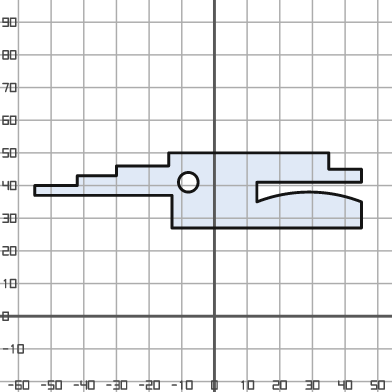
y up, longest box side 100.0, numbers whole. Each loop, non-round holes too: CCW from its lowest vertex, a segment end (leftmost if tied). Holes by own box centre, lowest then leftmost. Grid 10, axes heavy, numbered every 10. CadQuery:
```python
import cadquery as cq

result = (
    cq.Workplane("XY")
    .moveTo(-13.0, 27.0)
    .lineTo(45.0, 27.0)
    .lineTo(45.0, 35.0)
    .threePointArc((29.0, 38.0), (13.0, 35.0))
    .lineTo(13.0, 41.0)
    .lineTo(45.0, 41.0)
    .lineTo(45.0, 45.0)
    .lineTo(35.0, 45.0)
    .lineTo(35.0, 50.0)
    .lineTo(-14.0, 50.0)
    .lineTo(-14.0, 46.0)
    .lineTo(-30.0, 46.0)
    .lineTo(-30.0, 43.0)
    .lineTo(-42.0, 43.0)
    .lineTo(-42.0, 40.0)
    .lineTo(-55.0, 40.0)
    .lineTo(-55.0, 37.0)
    .lineTo(-13.0, 37.0)
    .close()
    .moveTo(-8.0, 41.0)
    .circle(3.0)
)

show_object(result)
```